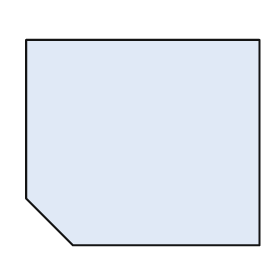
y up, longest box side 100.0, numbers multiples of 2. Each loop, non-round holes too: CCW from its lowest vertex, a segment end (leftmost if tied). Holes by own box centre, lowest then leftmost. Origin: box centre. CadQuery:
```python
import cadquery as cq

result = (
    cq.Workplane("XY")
    .moveTo(-30.0, -44.0)
    .lineTo(50.0, -44.0)
    .lineTo(50.0, 44.0)
    .lineTo(-50.0, 44.0)
    .lineTo(-50.0, -24.0)
    .close()
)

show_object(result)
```